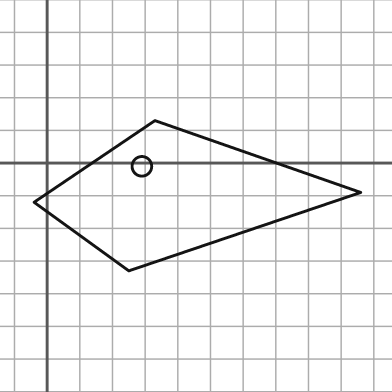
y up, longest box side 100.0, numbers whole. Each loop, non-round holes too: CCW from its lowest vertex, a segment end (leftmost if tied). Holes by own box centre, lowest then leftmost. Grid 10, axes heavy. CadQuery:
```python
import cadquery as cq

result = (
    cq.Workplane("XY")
    .moveTo(25.0, -33.0)
    .lineTo(96.0, -9.0)
    .lineTo(33.0, 13.0)
    .lineTo(-4.0, -12.0)
    .close()
    .moveTo(29.0, -1.0)
    .circle(3.0)
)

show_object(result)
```